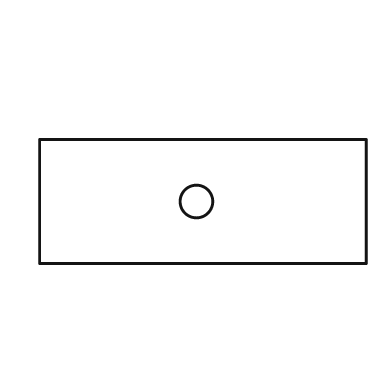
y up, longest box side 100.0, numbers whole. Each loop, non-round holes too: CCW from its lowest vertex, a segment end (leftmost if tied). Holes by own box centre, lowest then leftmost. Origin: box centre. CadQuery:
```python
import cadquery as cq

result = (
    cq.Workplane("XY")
    .moveTo(-50.0, -19.0)
    .lineTo(50.0, -19.0)
    .lineTo(50.0, 19.0)
    .lineTo(-50.0, 19.0)
    .close()
    .moveTo(-2.0, 0.0)
    .circle(5.0)
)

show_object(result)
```